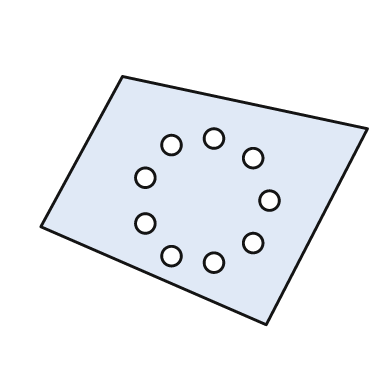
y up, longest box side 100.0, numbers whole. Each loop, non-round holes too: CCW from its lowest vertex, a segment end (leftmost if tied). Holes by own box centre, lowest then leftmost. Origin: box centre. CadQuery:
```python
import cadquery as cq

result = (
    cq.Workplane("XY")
    .moveTo(19.0, -38.0)
    .lineTo(50.0, 22.0)
    .lineTo(-25.0, 38.0)
    .lineTo(-50.0, -8.0)
    .close()
    .moveTo(3.0, -19.0)
    .circle(3.0)
    .moveTo(-10.0, -17.0)
    .circle(3.0)
    .moveTo(15.0, -13.0)
    .circle(3.0)
    .moveTo(-18.0, -7.0)
    .circle(3.0)
    .moveTo(20.0, 0.0)
    .circle(3.0)
    .moveTo(-18.0, 7.0)
    .circle(3.0)
    .moveTo(15.0, 13.0)
    .circle(3.0)
    .moveTo(-10.0, 17.0)
    .circle(3.0)
    .moveTo(3.0, 19.0)
    .circle(3.0)
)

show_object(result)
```